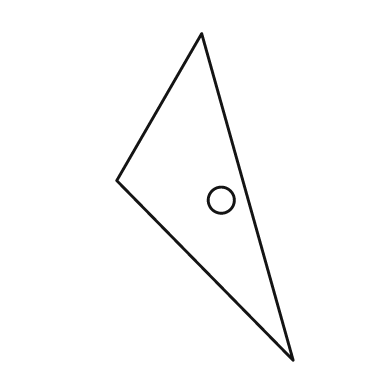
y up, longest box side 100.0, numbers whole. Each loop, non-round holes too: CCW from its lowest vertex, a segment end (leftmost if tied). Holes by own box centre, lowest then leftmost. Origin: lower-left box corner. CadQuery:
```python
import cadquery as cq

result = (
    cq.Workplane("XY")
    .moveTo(54.0, 0.0)
    .lineTo(26.0, 100.0)
    .lineTo(0.0, 55.0)
    .close()
    .moveTo(32.0, 49.0)
    .circle(4.0)
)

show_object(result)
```